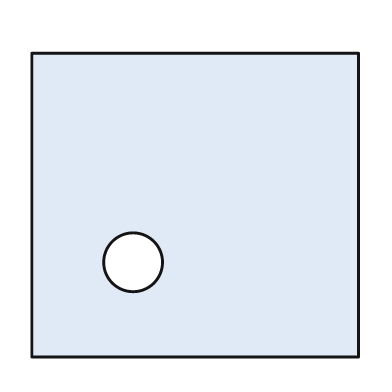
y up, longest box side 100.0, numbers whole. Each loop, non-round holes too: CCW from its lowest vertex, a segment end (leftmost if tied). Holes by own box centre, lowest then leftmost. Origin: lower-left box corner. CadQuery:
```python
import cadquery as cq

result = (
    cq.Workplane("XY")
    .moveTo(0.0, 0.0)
    .lineTo(100.0, 0.0)
    .lineTo(100.0, 93.0)
    .lineTo(0.0, 93.0)
    .close()
    .moveTo(31.0, 29.0)
    .circle(9.0)
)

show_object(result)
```